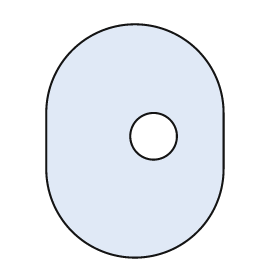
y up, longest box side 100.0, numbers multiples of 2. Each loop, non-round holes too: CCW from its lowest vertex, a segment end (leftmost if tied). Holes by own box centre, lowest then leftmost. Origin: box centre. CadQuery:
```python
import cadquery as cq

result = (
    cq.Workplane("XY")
    .moveTo(-38.0, -12.0)
    .threePointArc((0.0, -50.0), (38.0, -12.0))
    .lineTo(38.0, 12.0)
    .threePointArc((0.0, 50.0), (-38.0, 12.0))
    .close()
    .moveTo(8.0, 2.0)
    .circle(10.0)
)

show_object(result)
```